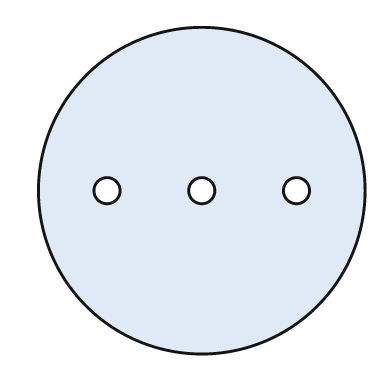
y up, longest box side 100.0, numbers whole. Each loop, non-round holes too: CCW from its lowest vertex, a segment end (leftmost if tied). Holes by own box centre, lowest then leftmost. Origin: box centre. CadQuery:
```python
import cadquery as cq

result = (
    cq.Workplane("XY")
    .moveTo(0.0, 0.0)
    .circle(50.0)
    .moveTo(-29.0, 0.0)
    .circle(4.0)
    .moveTo(0.0, 0.0)
    .circle(4.0)
    .moveTo(29.0, 0.0)
    .circle(4.0)
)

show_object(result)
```